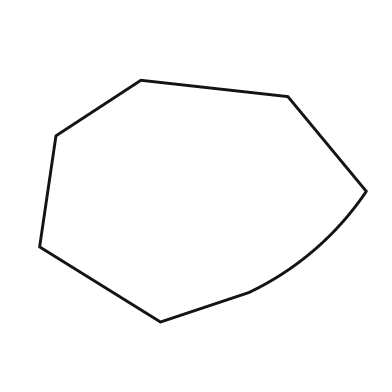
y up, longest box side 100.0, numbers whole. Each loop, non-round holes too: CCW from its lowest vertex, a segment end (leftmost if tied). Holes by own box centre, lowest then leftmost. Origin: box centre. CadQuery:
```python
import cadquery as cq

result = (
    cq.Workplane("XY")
    .moveTo(-13.0, -37.0)
    .lineTo(14.0, -28.0)
    .threePointArc((34.0, -15.0), (50.0, 3.0))
    .lineTo(26.0, 32.0)
    .lineTo(-19.0, 37.0)
    .lineTo(-45.0, 20.0)
    .lineTo(-50.0, -14.0)
    .close()
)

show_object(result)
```